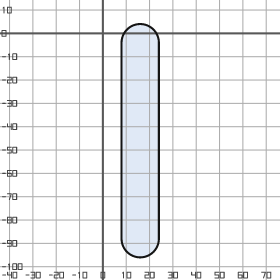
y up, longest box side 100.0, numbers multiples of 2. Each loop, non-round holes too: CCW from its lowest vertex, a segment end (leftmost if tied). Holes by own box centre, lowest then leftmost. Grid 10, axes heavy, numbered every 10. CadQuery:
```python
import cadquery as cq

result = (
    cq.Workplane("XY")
    .moveTo(8.0, -88.0)
    .threePointArc((16.0, -96.0), (24.0, -88.0))
    .lineTo(24.0, -4.0)
    .threePointArc((16.0, 4.0), (8.0, -4.0))
    .close()
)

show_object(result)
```